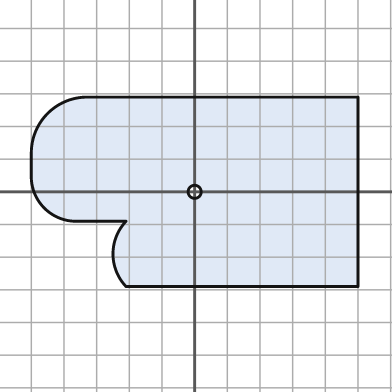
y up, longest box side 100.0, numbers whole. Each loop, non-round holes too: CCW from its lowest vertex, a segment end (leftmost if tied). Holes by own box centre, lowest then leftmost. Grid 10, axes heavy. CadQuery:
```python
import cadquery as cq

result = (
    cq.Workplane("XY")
    .moveTo(-21.0, -29.0)
    .lineTo(50.0, -29.0)
    .lineTo(50.0, 29.0)
    .lineTo(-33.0, 29.0)
    .threePointArc((-45.0, 24.0), (-50.0, 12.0))
    .lineTo(-50.0, 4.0)
    .threePointArc((-46.0, -5.0), (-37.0, -9.0))
    .lineTo(-21.0, -9.0)
    .threePointArc((-25.0, -19.0), (-21.0, -29.0))
    .close()
    .moveTo(0.0, 0.0)
    .circle(2.0)
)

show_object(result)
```